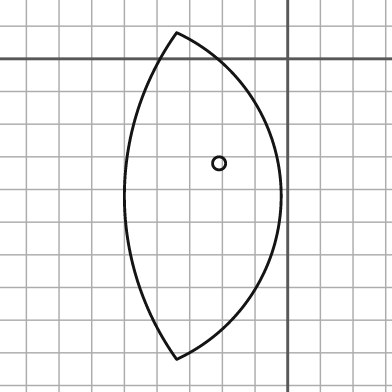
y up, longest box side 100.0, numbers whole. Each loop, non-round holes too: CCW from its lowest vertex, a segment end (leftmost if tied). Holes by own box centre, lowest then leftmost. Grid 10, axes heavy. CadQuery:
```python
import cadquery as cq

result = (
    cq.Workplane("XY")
    .moveTo(-34.0, -92.0)
    .threePointArc((-2.0, -42.0), (-34.0, 8.0))
    .threePointArc((-50.0, -42.0), (-34.0, -92.0))
    .close()
    .moveTo(-21.0, -32.0)
    .circle(2.0)
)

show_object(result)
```